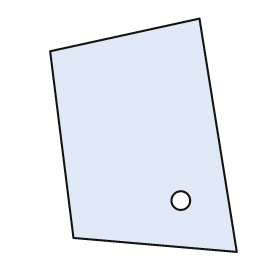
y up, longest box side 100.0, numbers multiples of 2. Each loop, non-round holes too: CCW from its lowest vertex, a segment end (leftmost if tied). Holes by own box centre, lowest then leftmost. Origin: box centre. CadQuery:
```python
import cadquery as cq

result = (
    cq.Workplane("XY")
    .moveTo(40.0, -50.0)
    .lineTo(24.0, 50.0)
    .lineTo(-40.0, 36.0)
    .lineTo(-30.0, -44.0)
    .close()
    .moveTo(16.0, -28.0)
    .circle(4.0)
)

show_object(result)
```